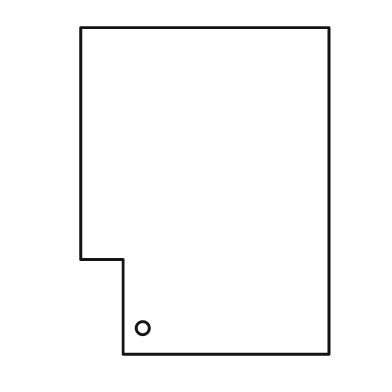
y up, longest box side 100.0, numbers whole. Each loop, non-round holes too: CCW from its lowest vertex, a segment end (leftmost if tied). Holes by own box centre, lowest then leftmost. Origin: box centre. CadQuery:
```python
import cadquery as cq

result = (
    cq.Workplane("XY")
    .moveTo(-25.0, -50.0)
    .lineTo(38.0, -50.0)
    .lineTo(38.0, 50.0)
    .lineTo(-38.0, 50.0)
    .lineTo(-38.0, -21.0)
    .lineTo(-25.0, -21.0)
    .close()
    .moveTo(-19.0, -42.0)
    .circle(2.0)
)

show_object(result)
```